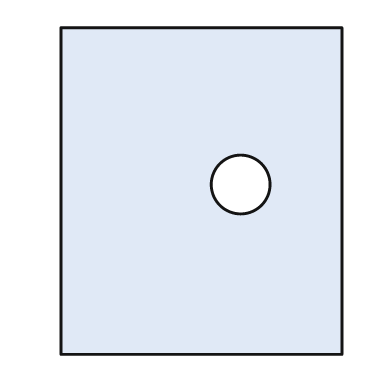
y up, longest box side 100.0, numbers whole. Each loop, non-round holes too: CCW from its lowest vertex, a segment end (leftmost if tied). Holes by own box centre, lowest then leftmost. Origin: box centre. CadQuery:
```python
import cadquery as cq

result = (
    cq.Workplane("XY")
    .moveTo(-43.0, -50.0)
    .lineTo(43.0, -50.0)
    .lineTo(43.0, 50.0)
    .lineTo(-43.0, 50.0)
    .close()
    .moveTo(12.0, 2.0)
    .circle(9.0)
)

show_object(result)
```